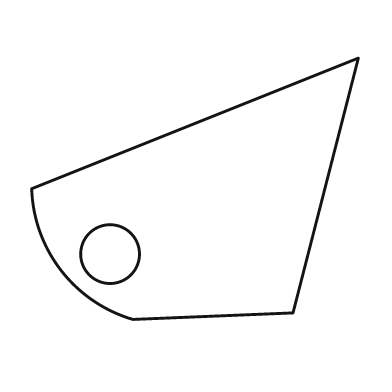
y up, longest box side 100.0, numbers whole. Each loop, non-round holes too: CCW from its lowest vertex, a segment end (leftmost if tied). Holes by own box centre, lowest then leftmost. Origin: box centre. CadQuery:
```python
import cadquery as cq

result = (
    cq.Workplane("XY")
    .moveTo(-19.0, -40.0)
    .lineTo(30.0, -38.0)
    .lineTo(50.0, 40.0)
    .lineTo(-50.0, 0.0)
    .threePointArc((-41.0, -25.0), (-19.0, -40.0))
    .close()
    .moveTo(-26.0, -20.0)
    .circle(9.0)
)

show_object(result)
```